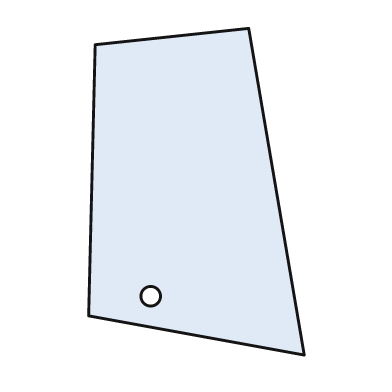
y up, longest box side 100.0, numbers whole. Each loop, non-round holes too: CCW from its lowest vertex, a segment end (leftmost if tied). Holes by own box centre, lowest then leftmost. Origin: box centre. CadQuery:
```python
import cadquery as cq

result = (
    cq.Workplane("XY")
    .moveTo(33.0, -50.0)
    .lineTo(16.0, 50.0)
    .lineTo(-31.0, 45.0)
    .lineTo(-33.0, -38.0)
    .close()
    .moveTo(-14.0, -32.0)
    .circle(3.0)
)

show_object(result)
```